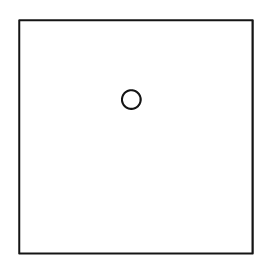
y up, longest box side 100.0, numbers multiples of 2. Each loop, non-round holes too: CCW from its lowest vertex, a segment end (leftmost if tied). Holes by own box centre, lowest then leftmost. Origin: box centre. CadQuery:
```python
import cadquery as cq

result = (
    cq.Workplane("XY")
    .moveTo(-50.0, -50.0)
    .lineTo(50.0, -50.0)
    .lineTo(50.0, 50.0)
    .lineTo(-50.0, 50.0)
    .close()
    .moveTo(-2.0, 16.0)
    .circle(4.0)
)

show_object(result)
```